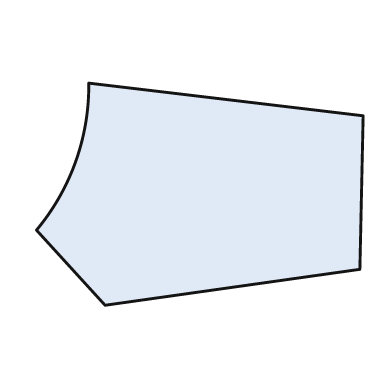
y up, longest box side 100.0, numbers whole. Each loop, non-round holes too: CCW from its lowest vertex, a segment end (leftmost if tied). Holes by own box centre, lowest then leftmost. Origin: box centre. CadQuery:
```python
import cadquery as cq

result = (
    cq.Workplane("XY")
    .moveTo(-29.0, -34.0)
    .lineTo(49.0, -23.0)
    .lineTo(50.0, 24.0)
    .lineTo(-34.0, 34.0)
    .threePointArc((-38.0, 10.0), (-50.0, -11.0))
    .close()
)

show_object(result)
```